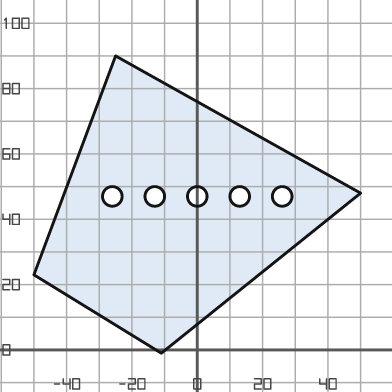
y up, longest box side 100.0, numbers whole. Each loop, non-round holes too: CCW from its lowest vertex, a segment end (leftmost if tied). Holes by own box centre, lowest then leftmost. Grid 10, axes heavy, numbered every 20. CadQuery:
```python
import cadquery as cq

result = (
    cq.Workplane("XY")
    .moveTo(-11.0, -1.0)
    .lineTo(50.0, 48.0)
    .lineTo(-25.0, 90.0)
    .lineTo(-50.0, 23.0)
    .close()
    .moveTo(-26.0, 47.0)
    .circle(3.0)
    .moveTo(-13.0, 47.0)
    .circle(3.0)
    .moveTo(0.0, 47.0)
    .circle(3.0)
    .moveTo(13.0, 47.0)
    .circle(3.0)
    .moveTo(26.0, 47.0)
    .circle(3.0)
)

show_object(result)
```